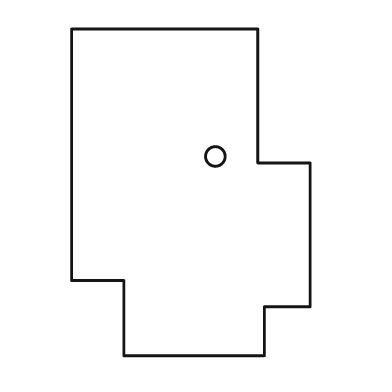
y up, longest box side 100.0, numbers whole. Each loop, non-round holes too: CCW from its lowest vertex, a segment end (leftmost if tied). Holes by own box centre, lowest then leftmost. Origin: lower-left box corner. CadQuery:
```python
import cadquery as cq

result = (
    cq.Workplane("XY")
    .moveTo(16.0, 0.0)
    .lineTo(59.0, 0.0)
    .lineTo(59.0, 15.0)
    .lineTo(73.0, 15.0)
    .lineTo(73.0, 59.0)
    .lineTo(57.0, 59.0)
    .lineTo(57.0, 100.0)
    .lineTo(0.0, 100.0)
    .lineTo(0.0, 23.0)
    .lineTo(16.0, 23.0)
    .close()
    .moveTo(44.0, 61.0)
    .circle(3.0)
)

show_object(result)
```